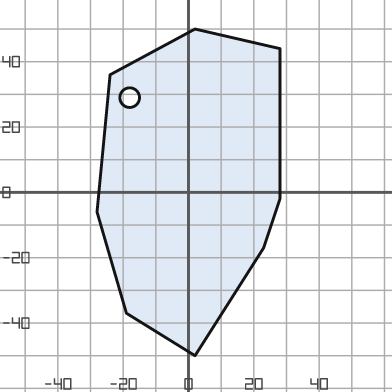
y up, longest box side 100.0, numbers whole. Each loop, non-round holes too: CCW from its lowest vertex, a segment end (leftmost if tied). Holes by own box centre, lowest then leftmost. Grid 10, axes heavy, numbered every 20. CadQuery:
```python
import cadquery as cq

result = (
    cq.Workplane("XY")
    .moveTo(2.0, -50.0)
    .lineTo(23.0, -17.0)
    .lineTo(28.0, -2.0)
    .lineTo(28.0, 44.0)
    .lineTo(2.0, 50.0)
    .lineTo(-24.0, 36.0)
    .lineTo(-28.0, -6.0)
    .lineTo(-19.0, -37.0)
    .close()
    .moveTo(-18.0, 29.0)
    .circle(3.0)
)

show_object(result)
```